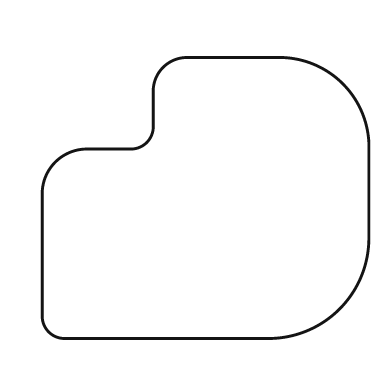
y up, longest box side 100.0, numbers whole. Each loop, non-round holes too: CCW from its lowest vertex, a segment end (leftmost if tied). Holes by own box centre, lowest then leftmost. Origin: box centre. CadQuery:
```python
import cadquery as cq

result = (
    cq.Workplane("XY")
    .moveTo(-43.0, -43.0)
    .lineTo(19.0, -43.0)
    .threePointArc((41.0, -34.0), (50.0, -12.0))
    .lineTo(50.0, 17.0)
    .threePointArc((42.0, 35.0), (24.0, 43.0))
    .lineTo(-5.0, 43.0)
    .threePointArc((-13.0, 40.0), (-16.0, 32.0))
    .lineTo(-16.0, 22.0)
    .threePointArc((-18.0, 17.0), (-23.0, 15.0))
    .lineTo(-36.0, 15.0)
    .threePointArc((-46.0, 11.0), (-50.0, 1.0))
    .lineTo(-50.0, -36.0)
    .threePointArc((-48.0, -41.0), (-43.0, -43.0))
    .close()
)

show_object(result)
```